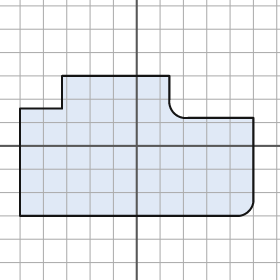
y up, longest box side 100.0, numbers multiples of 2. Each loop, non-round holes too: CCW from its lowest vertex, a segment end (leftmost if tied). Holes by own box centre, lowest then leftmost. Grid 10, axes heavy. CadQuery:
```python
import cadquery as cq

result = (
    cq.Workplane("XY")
    .moveTo(-50.0, -30.0)
    .lineTo(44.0, -30.0)
    .threePointArc((48.0, -28.0), (50.0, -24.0))
    .lineTo(50.0, 12.0)
    .lineTo(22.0, 12.0)
    .threePointArc((16.0, 14.0), (14.0, 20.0))
    .lineTo(14.0, 30.0)
    .lineTo(-32.0, 30.0)
    .lineTo(-32.0, 16.0)
    .lineTo(-50.0, 16.0)
    .close()
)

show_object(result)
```